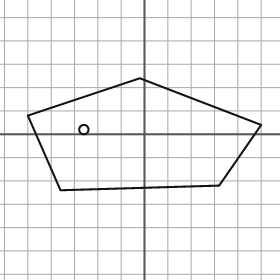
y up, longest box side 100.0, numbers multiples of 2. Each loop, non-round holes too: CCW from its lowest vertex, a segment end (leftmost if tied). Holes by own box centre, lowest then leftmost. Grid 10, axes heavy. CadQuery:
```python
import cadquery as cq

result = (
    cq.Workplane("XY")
    .moveTo(-36.0, -24.0)
    .lineTo(32.0, -22.0)
    .lineTo(50.0, 4.0)
    .lineTo(-2.0, 24.0)
    .lineTo(-50.0, 8.0)
    .close()
    .moveTo(-26.0, 2.0)
    .circle(2.0)
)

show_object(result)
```